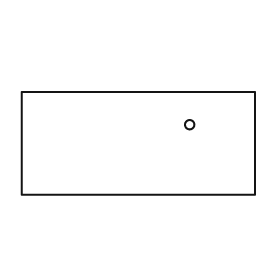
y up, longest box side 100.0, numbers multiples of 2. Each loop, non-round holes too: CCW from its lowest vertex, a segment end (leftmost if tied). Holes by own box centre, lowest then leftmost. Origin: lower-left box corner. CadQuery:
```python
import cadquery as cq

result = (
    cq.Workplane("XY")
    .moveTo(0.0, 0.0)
    .lineTo(100.0, 0.0)
    .lineTo(100.0, 44.0)
    .lineTo(0.0, 44.0)
    .close()
    .moveTo(72.0, 30.0)
    .circle(2.0)
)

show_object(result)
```